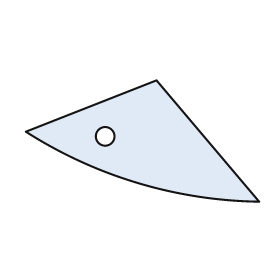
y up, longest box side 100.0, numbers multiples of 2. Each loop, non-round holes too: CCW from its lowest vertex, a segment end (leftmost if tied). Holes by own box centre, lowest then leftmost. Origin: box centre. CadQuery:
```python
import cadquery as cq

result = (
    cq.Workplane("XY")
    .moveTo(50.0, -26.0)
    .lineTo(6.0, 26.0)
    .lineTo(-50.0, 4.0)
    .threePointArc((-2.0, -18.0), (50.0, -26.0))
    .close()
    .moveTo(-16.0, 2.0)
    .circle(4.0)
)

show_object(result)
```